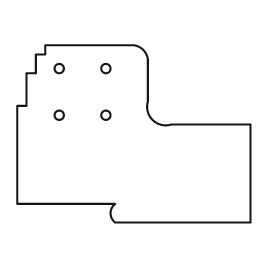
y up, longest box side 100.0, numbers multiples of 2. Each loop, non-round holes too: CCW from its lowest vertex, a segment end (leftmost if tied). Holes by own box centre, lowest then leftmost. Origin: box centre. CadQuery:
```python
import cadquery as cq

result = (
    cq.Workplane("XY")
    .moveTo(-8.0, -38.0)
    .lineTo(50.0, -38.0)
    .lineTo(50.0, 4.0)
    .lineTo(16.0, 4.0)
    .threePointArc((8.0, 6.0), (6.0, 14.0))
    .lineTo(6.0, 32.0)
    .threePointArc((4.0, 36.0), (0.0, 38.0))
    .lineTo(-38.0, 38.0)
    .lineTo(-38.0, 34.0)
    .lineTo(-42.0, 34.0)
    .lineTo(-42.0, 26.0)
    .lineTo(-46.0, 26.0)
    .lineTo(-46.0, 12.0)
    .lineTo(-50.0, 12.0)
    .lineTo(-50.0, -30.0)
    .lineTo(-8.0, -30.0)
    .threePointArc((-10.0, -34.0), (-8.0, -38.0))
    .close()
    .moveTo(-32.0, 8.0)
    .circle(2.0)
    .moveTo(-12.0, 8.0)
    .circle(2.0)
    .moveTo(-32.0, 28.0)
    .circle(2.0)
    .moveTo(-12.0, 28.0)
    .circle(2.0)
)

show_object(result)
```